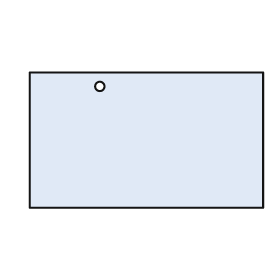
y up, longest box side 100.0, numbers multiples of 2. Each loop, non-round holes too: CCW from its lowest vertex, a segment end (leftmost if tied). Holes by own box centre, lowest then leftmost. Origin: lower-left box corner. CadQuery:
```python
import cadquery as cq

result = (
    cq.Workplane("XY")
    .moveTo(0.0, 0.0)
    .lineTo(100.0, 0.0)
    .lineTo(100.0, 58.0)
    .lineTo(0.0, 58.0)
    .close()
    .moveTo(30.0, 52.0)
    .circle(2.0)
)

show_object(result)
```